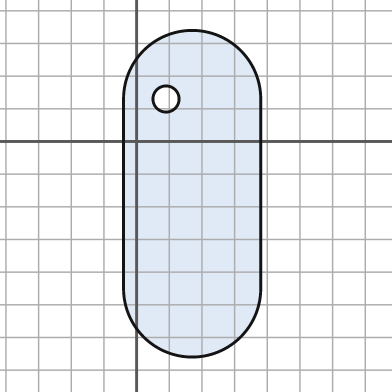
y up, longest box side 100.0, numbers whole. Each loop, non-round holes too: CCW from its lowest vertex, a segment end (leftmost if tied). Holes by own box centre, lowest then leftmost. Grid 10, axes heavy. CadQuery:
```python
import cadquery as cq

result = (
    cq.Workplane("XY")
    .moveTo(-4.0, -45.0)
    .threePointArc((17.0, -66.0), (38.0, -45.0))
    .lineTo(38.0, 13.0)
    .threePointArc((17.0, 34.0), (-4.0, 13.0))
    .close()
    .moveTo(9.0, 13.0)
    .circle(4.0)
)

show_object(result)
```